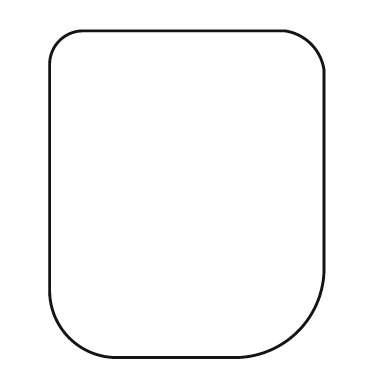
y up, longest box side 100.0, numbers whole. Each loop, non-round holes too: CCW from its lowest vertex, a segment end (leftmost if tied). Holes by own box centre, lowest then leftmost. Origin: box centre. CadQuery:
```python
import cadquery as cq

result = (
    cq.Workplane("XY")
    .moveTo(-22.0, -50.0)
    .lineTo(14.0, -50.0)
    .threePointArc((34.0, -42.0), (42.0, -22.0))
    .lineTo(42.0, 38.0)
    .threePointArc((38.0, 46.0), (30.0, 50.0))
    .lineTo(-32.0, 50.0)
    .threePointArc((-39.0, 47.0), (-42.0, 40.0))
    .lineTo(-42.0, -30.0)
    .threePointArc((-36.0, -44.0), (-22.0, -50.0))
    .close()
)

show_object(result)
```